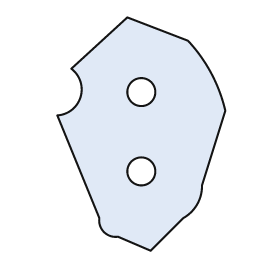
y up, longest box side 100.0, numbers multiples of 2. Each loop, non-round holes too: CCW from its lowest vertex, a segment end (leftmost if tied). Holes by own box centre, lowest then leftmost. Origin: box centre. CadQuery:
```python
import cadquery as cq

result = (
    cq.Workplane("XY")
    .moveTo(4.0, -50.0)
    .lineTo(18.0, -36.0)
    .threePointArc((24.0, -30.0), (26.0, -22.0))
    .lineTo(36.0, 10.0)
    .threePointArc((30.0, 26.0), (20.0, 40.0))
    .lineTo(-6.0, 50.0)
    .lineTo(-30.0, 28.0)
    .threePointArc((-26.0, 16.0), (-36.0, 8.0))
    .lineTo(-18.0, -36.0)
    .threePointArc((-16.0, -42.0), (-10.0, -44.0))
    .close()
    .moveTo(0.0, -16.0)
    .circle(6.0)
    .moveTo(0.0, 18.0)
    .circle(6.0)
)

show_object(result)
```